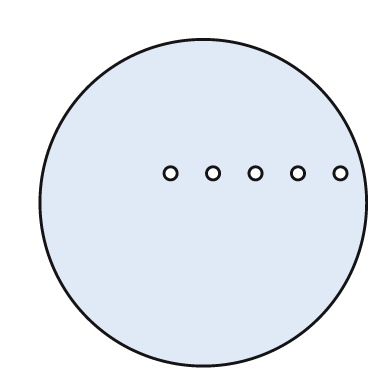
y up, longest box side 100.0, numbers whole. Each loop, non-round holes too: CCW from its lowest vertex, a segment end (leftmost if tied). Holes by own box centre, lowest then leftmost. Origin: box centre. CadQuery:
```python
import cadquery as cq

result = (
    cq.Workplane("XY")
    .moveTo(0.0, 0.0)
    .circle(50.0)
    .moveTo(-10.0, 9.0)
    .circle(2.0)
    .moveTo(3.0, 9.0)
    .circle(2.0)
    .moveTo(16.0, 9.0)
    .circle(2.0)
    .moveTo(29.0, 9.0)
    .circle(2.0)
    .moveTo(42.0, 9.0)
    .circle(2.0)
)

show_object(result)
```